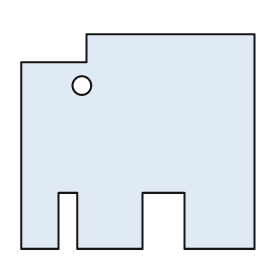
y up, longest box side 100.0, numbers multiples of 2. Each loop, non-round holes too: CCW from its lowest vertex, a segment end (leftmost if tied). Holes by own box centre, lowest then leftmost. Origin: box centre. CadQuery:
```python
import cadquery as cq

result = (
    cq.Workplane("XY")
    .moveTo(-50.0, -46.0)
    .lineTo(-34.0, -46.0)
    .lineTo(-34.0, -22.0)
    .lineTo(-26.0, -22.0)
    .lineTo(-26.0, -46.0)
    .lineTo(2.0, -46.0)
    .lineTo(2.0, -22.0)
    .lineTo(20.0, -22.0)
    .lineTo(20.0, -46.0)
    .lineTo(50.0, -46.0)
    .lineTo(50.0, 46.0)
    .lineTo(-22.0, 46.0)
    .lineTo(-22.0, 34.0)
    .lineTo(-50.0, 34.0)
    .close()
    .moveTo(-24.0, 24.0)
    .circle(4.0)
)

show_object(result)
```